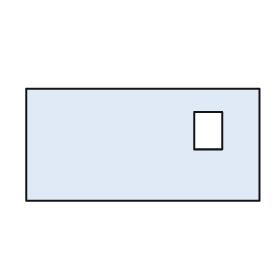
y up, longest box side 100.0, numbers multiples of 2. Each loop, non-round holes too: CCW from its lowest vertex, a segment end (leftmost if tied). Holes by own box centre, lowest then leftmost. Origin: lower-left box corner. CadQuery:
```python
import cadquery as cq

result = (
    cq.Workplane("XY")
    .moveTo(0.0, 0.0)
    .lineTo(100.0, 0.0)
    .lineTo(100.0, 48.0)
    .lineTo(0.0, 48.0)
    .close()
    .moveTo(72.0, 22.0)
    .lineTo(84.0, 22.0)
    .lineTo(84.0, 38.0)
    .lineTo(72.0, 38.0)
    .close()
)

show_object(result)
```